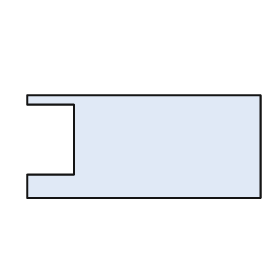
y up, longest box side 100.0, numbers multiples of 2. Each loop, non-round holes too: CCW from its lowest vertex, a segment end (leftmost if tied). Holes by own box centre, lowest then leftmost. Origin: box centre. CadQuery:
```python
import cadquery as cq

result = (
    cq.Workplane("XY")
    .moveTo(-50.0, -22.0)
    .lineTo(50.0, -22.0)
    .lineTo(50.0, 22.0)
    .lineTo(-50.0, 22.0)
    .lineTo(-50.0, 18.0)
    .lineTo(-30.0, 18.0)
    .lineTo(-30.0, -12.0)
    .lineTo(-50.0, -12.0)
    .close()
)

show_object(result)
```